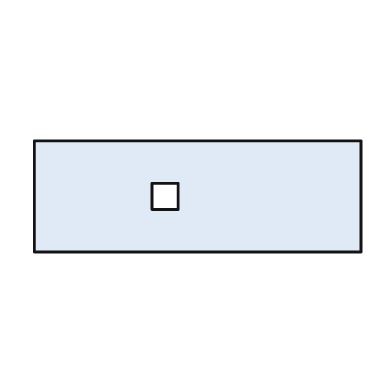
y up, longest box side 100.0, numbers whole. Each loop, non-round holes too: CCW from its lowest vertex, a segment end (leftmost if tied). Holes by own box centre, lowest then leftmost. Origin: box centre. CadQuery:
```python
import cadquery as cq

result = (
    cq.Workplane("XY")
    .moveTo(-50.0, -17.0)
    .lineTo(50.0, -17.0)
    .lineTo(50.0, 17.0)
    .lineTo(-50.0, 17.0)
    .close()
    .moveTo(-14.0, -4.0)
    .lineTo(-6.0, -4.0)
    .lineTo(-6.0, 4.0)
    .lineTo(-14.0, 4.0)
    .close()
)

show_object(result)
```